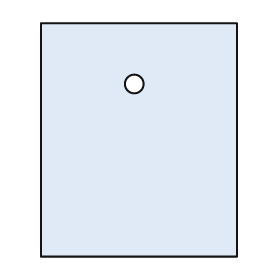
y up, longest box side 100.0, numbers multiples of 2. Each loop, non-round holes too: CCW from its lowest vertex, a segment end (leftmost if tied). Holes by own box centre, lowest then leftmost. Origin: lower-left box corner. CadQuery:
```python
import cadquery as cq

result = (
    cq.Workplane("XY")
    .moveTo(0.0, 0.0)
    .lineTo(84.0, 0.0)
    .lineTo(84.0, 100.0)
    .lineTo(0.0, 100.0)
    .close()
    .moveTo(40.0, 74.0)
    .circle(4.0)
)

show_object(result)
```